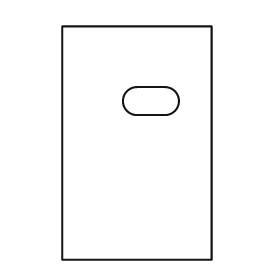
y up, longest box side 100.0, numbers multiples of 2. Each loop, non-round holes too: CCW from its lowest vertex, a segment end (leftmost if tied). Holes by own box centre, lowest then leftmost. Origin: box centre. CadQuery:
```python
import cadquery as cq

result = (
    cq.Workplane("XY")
    .moveTo(-32.0, -50.0)
    .lineTo(32.0, -50.0)
    .lineTo(32.0, 50.0)
    .lineTo(-32.0, 50.0)
    .close()
    .moveTo(0.0, 12.0)
    .lineTo(12.0, 12.0)
    .threePointArc((18.0, 18.0), (12.0, 24.0))
    .lineTo(0.0, 24.0)
    .threePointArc((-6.0, 18.0), (0.0, 12.0))
    .close()
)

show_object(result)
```